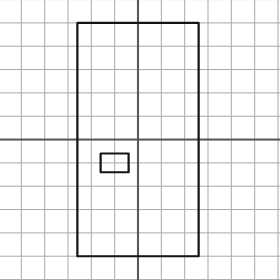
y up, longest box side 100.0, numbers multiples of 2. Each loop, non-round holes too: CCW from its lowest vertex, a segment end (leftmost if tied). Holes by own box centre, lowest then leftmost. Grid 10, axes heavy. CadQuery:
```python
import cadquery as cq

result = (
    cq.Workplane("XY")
    .moveTo(-26.0, -50.0)
    .lineTo(26.0, -50.0)
    .lineTo(26.0, 50.0)
    .lineTo(-26.0, 50.0)
    .close()
    .moveTo(-16.0, -14.0)
    .lineTo(-4.0, -14.0)
    .lineTo(-4.0, -6.0)
    .lineTo(-16.0, -6.0)
    .close()
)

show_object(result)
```